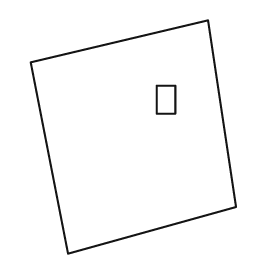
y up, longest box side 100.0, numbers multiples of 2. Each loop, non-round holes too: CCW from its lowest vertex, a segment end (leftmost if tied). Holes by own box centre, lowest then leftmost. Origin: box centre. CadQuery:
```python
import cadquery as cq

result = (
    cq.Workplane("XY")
    .moveTo(-28.0, -50.0)
    .lineTo(44.0, -30.0)
    .lineTo(32.0, 50.0)
    .lineTo(-44.0, 32.0)
    .close()
    .moveTo(10.0, 10.0)
    .lineTo(18.0, 10.0)
    .lineTo(18.0, 22.0)
    .lineTo(10.0, 22.0)
    .close()
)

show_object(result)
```